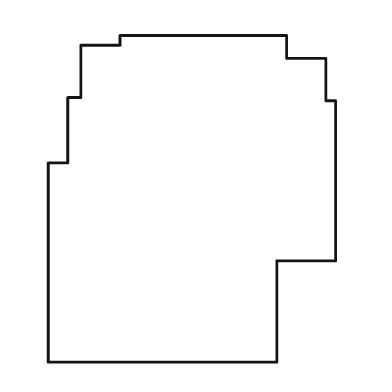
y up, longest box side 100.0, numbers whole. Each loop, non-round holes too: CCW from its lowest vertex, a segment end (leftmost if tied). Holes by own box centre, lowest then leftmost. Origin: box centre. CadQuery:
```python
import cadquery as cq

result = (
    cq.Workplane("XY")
    .moveTo(-44.0, -50.0)
    .lineTo(26.0, -50.0)
    .lineTo(26.0, -19.0)
    .lineTo(44.0, -19.0)
    .lineTo(44.0, 30.0)
    .lineTo(41.0, 30.0)
    .lineTo(41.0, 43.0)
    .lineTo(29.0, 43.0)
    .lineTo(29.0, 50.0)
    .lineTo(-22.0, 50.0)
    .lineTo(-22.0, 47.0)
    .lineTo(-34.0, 47.0)
    .lineTo(-34.0, 31.0)
    .lineTo(-38.0, 31.0)
    .lineTo(-38.0, 11.0)
    .lineTo(-44.0, 11.0)
    .close()
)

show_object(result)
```